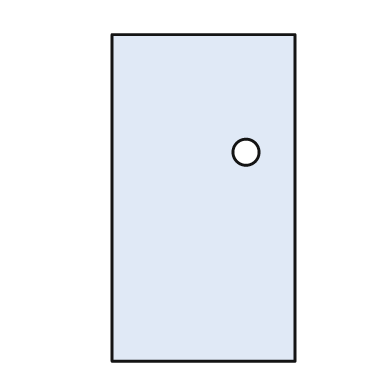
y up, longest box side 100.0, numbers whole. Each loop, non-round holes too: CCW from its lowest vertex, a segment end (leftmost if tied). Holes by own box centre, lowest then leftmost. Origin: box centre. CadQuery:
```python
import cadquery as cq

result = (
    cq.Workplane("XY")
    .moveTo(-28.0, -50.0)
    .lineTo(28.0, -50.0)
    .lineTo(28.0, 50.0)
    .lineTo(-28.0, 50.0)
    .close()
    .moveTo(13.0, 14.0)
    .circle(4.0)
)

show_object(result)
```